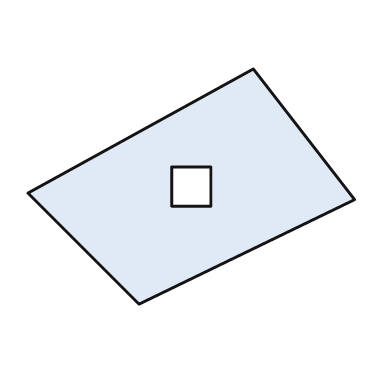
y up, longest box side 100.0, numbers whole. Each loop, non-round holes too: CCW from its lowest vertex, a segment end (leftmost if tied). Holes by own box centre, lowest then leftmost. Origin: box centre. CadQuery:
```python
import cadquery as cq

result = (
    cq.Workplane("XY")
    .moveTo(-16.0, -36.0)
    .lineTo(50.0, -4.0)
    .lineTo(19.0, 36.0)
    .lineTo(-50.0, -2.0)
    .close()
    .moveTo(-6.0, -6.0)
    .lineTo(6.0, -6.0)
    .lineTo(6.0, 6.0)
    .lineTo(-6.0, 6.0)
    .close()
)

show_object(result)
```